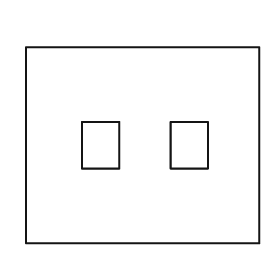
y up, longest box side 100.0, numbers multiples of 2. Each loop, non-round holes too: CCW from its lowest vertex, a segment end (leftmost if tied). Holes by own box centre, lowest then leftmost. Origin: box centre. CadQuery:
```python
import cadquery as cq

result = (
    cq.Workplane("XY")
    .moveTo(-50.0, -42.0)
    .lineTo(50.0, -42.0)
    .lineTo(50.0, 42.0)
    .lineTo(-50.0, 42.0)
    .close()
    .moveTo(-26.0, -10.0)
    .lineTo(-10.0, -10.0)
    .lineTo(-10.0, 10.0)
    .lineTo(-26.0, 10.0)
    .close()
    .moveTo(12.0, -10.0)
    .lineTo(28.0, -10.0)
    .lineTo(28.0, 10.0)
    .lineTo(12.0, 10.0)
    .close()
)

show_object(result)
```